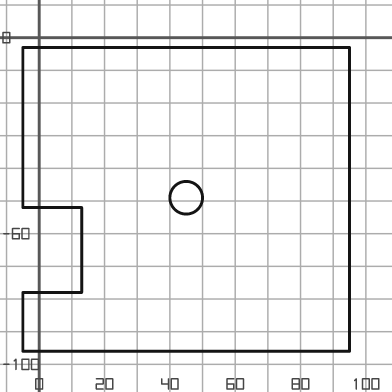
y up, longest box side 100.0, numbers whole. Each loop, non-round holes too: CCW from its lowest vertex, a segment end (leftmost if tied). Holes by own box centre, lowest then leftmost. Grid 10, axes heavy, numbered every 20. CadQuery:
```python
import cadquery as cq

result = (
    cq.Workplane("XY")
    .moveTo(-5.0, -96.0)
    .lineTo(95.0, -96.0)
    .lineTo(95.0, -3.0)
    .lineTo(-5.0, -3.0)
    .lineTo(-5.0, -52.0)
    .lineTo(13.0, -52.0)
    .lineTo(13.0, -78.0)
    .lineTo(-5.0, -78.0)
    .close()
    .moveTo(45.0, -49.0)
    .circle(5.0)
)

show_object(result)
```